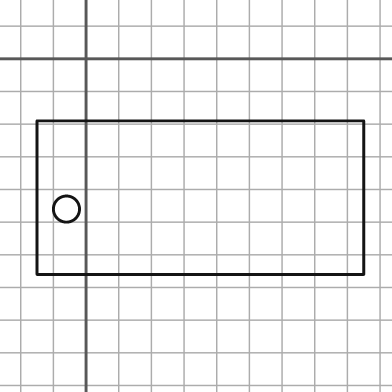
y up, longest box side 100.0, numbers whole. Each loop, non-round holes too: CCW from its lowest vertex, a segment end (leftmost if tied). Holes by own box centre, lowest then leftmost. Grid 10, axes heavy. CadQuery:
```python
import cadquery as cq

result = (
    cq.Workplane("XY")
    .moveTo(-15.0, -66.0)
    .lineTo(85.0, -66.0)
    .lineTo(85.0, -19.0)
    .lineTo(-15.0, -19.0)
    .close()
    .moveTo(-6.0, -46.0)
    .circle(4.0)
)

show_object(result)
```